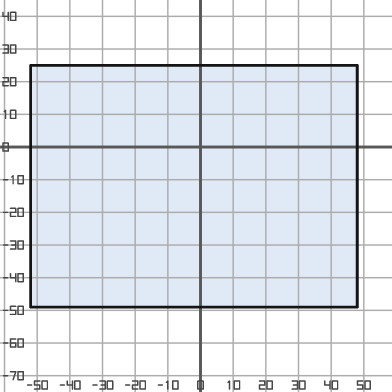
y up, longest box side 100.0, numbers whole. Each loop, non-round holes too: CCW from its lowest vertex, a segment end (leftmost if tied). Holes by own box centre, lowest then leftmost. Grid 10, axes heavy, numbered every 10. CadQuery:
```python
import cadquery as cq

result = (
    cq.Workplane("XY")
    .moveTo(-52.0, -49.0)
    .lineTo(48.0, -49.0)
    .lineTo(48.0, 25.0)
    .lineTo(-52.0, 25.0)
    .close()
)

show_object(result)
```